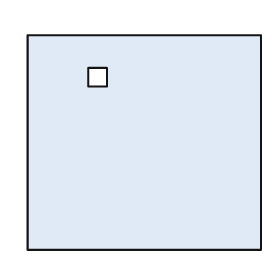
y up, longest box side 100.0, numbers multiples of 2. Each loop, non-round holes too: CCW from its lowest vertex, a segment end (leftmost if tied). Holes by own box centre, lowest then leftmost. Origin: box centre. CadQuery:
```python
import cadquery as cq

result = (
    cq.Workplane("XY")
    .moveTo(-50.0, -46.0)
    .lineTo(50.0, -46.0)
    .lineTo(50.0, 46.0)
    .lineTo(-50.0, 46.0)
    .close()
    .moveTo(-24.0, 24.0)
    .lineTo(-16.0, 24.0)
    .lineTo(-16.0, 32.0)
    .lineTo(-24.0, 32.0)
    .close()
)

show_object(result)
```